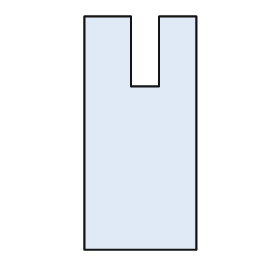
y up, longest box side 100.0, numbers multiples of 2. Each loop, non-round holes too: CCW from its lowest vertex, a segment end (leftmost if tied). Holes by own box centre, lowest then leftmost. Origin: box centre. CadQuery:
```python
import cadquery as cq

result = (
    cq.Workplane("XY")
    .moveTo(-24.0, -50.0)
    .lineTo(24.0, -50.0)
    .lineTo(24.0, 50.0)
    .lineTo(8.0, 50.0)
    .lineTo(8.0, 20.0)
    .lineTo(-4.0, 20.0)
    .lineTo(-4.0, 50.0)
    .lineTo(-24.0, 50.0)
    .close()
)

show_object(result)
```